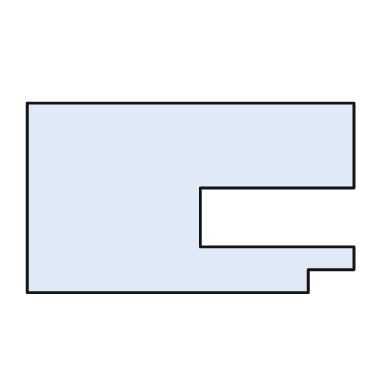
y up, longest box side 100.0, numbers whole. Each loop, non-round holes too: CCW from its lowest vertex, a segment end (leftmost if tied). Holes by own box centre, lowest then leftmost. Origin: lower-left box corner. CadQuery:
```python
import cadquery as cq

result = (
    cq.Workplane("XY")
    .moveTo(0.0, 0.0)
    .lineTo(86.0, 0.0)
    .lineTo(86.0, 7.0)
    .lineTo(100.0, 7.0)
    .lineTo(100.0, 14.0)
    .lineTo(53.0, 14.0)
    .lineTo(53.0, 32.0)
    .lineTo(100.0, 32.0)
    .lineTo(100.0, 58.0)
    .lineTo(0.0, 58.0)
    .close()
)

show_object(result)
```